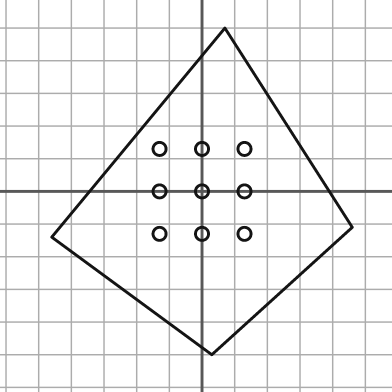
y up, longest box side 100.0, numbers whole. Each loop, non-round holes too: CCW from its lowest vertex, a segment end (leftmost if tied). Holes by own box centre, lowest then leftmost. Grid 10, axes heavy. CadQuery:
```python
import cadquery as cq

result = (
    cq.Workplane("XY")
    .moveTo(3.0, -50.0)
    .lineTo(46.0, -11.0)
    .lineTo(7.0, 50.0)
    .lineTo(-46.0, -14.0)
    .close()
    .moveTo(-13.0, -13.0)
    .circle(2.0)
    .moveTo(0.0, -13.0)
    .circle(2.0)
    .moveTo(13.0, -13.0)
    .circle(2.0)
    .moveTo(-13.0, 0.0)
    .circle(2.0)
    .moveTo(0.0, 0.0)
    .circle(2.0)
    .moveTo(13.0, 0.0)
    .circle(2.0)
    .moveTo(-13.0, 13.0)
    .circle(2.0)
    .moveTo(0.0, 13.0)
    .circle(2.0)
    .moveTo(13.0, 13.0)
    .circle(2.0)
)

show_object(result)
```